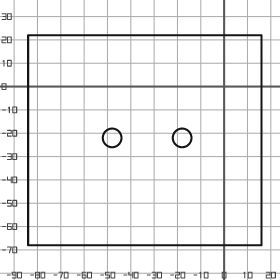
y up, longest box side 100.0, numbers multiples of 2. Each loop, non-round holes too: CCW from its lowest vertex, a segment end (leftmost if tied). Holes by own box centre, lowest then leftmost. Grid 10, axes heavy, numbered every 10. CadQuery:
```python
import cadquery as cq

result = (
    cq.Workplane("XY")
    .moveTo(-84.0, -68.0)
    .lineTo(16.0, -68.0)
    .lineTo(16.0, 22.0)
    .lineTo(-84.0, 22.0)
    .close()
    .moveTo(-48.0, -22.0)
    .circle(4.0)
    .moveTo(-18.0, -22.0)
    .circle(4.0)
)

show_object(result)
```